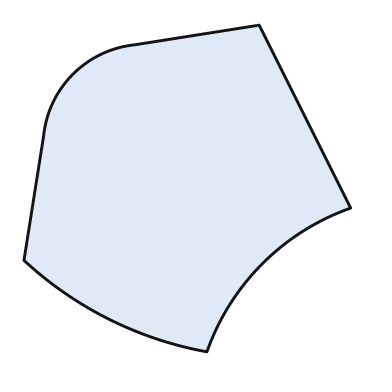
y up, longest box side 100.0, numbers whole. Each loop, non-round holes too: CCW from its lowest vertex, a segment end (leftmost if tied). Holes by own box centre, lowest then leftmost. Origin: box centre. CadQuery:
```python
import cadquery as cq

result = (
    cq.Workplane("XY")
    .moveTo(6.0, -50.0)
    .threePointArc((23.0, -23.0), (50.0, -6.0))
    .lineTo(22.0, 50.0)
    .lineTo(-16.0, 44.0)
    .threePointArc((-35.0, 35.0), (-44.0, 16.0))
    .lineTo(-50.0, -22.0)
    .threePointArc((-24.0, -40.0), (6.0, -50.0))
    .close()
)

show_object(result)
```